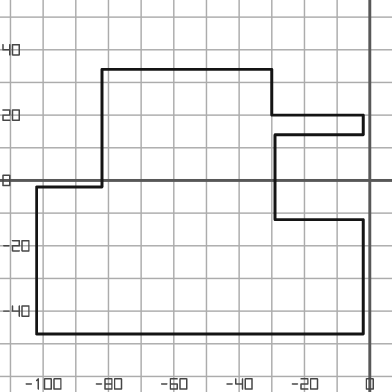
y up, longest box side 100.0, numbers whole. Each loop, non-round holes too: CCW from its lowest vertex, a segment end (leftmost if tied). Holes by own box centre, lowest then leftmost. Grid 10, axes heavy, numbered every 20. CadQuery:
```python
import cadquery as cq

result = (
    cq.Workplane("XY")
    .moveTo(-102.0, -47.0)
    .lineTo(-2.0, -47.0)
    .lineTo(-2.0, -12.0)
    .lineTo(-29.0, -12.0)
    .lineTo(-29.0, 14.0)
    .lineTo(-2.0, 14.0)
    .lineTo(-2.0, 20.0)
    .lineTo(-30.0, 20.0)
    .lineTo(-30.0, 34.0)
    .lineTo(-82.0, 34.0)
    .lineTo(-82.0, -2.0)
    .lineTo(-102.0, -2.0)
    .close()
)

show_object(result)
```